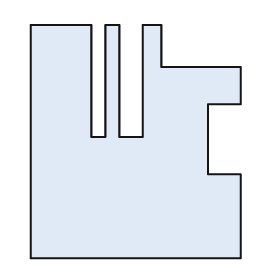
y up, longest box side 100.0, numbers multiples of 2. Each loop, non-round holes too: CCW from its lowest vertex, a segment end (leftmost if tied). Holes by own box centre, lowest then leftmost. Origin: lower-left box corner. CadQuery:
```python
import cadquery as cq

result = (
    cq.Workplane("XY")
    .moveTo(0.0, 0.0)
    .lineTo(90.0, 0.0)
    .lineTo(90.0, 36.0)
    .lineTo(76.0, 36.0)
    .lineTo(76.0, 66.0)
    .lineTo(90.0, 66.0)
    .lineTo(90.0, 82.0)
    .lineTo(56.0, 82.0)
    .lineTo(56.0, 100.0)
    .lineTo(48.0, 100.0)
    .lineTo(48.0, 52.0)
    .lineTo(38.0, 52.0)
    .lineTo(38.0, 100.0)
    .lineTo(32.0, 100.0)
    .lineTo(32.0, 52.0)
    .lineTo(26.0, 52.0)
    .lineTo(26.0, 100.0)
    .lineTo(0.0, 100.0)
    .close()
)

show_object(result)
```